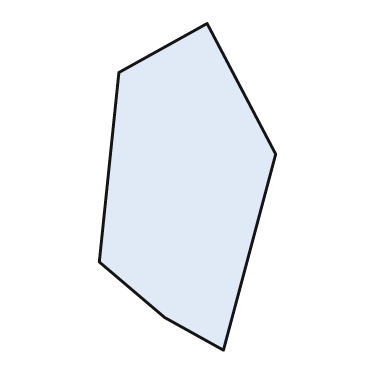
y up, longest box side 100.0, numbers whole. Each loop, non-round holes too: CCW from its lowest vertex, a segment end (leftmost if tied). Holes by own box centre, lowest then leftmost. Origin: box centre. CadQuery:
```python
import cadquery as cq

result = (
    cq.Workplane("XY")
    .moveTo(11.0, -50.0)
    .lineTo(27.0, 10.0)
    .lineTo(6.0, 50.0)
    .lineTo(-21.0, 35.0)
    .lineTo(-27.0, -23.0)
    .lineTo(-7.0, -40.0)
    .close()
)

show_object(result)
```